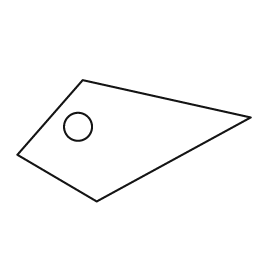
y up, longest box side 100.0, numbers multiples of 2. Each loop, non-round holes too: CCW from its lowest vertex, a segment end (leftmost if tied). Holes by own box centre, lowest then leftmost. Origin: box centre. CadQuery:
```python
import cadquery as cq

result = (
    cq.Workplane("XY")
    .moveTo(-16.0, -26.0)
    .lineTo(50.0, 10.0)
    .lineTo(-22.0, 26.0)
    .lineTo(-50.0, -6.0)
    .close()
    .moveTo(-24.0, 6.0)
    .circle(6.0)
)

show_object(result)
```